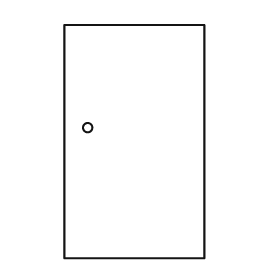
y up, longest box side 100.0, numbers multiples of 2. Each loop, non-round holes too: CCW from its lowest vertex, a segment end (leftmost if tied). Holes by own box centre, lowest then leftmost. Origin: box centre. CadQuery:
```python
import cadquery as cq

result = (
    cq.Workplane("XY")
    .moveTo(-30.0, -50.0)
    .lineTo(30.0, -50.0)
    .lineTo(30.0, 50.0)
    .lineTo(-30.0, 50.0)
    .close()
    .moveTo(-20.0, 6.0)
    .circle(2.0)
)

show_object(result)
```